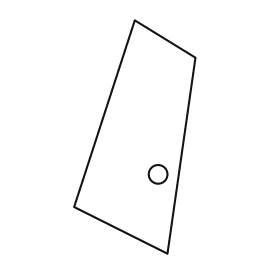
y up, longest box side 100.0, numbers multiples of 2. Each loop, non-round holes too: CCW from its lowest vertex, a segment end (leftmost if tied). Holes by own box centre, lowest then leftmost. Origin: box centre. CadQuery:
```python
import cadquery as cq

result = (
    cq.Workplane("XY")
    .moveTo(14.0, -50.0)
    .lineTo(26.0, 34.0)
    .lineTo(0.0, 50.0)
    .lineTo(-26.0, -30.0)
    .close()
    .moveTo(10.0, -16.0)
    .circle(4.0)
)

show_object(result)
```